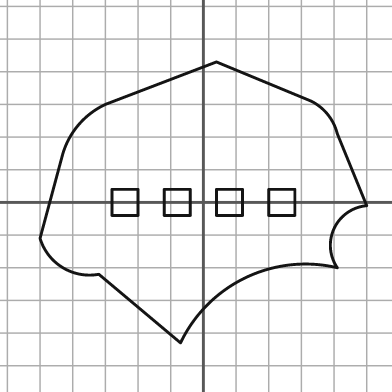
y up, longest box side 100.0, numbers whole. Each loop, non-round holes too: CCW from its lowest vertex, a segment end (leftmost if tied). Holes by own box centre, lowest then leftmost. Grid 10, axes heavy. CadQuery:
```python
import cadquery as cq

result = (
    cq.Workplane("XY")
    .moveTo(-7.0, -43.0)
    .threePointArc((13.0, -23.0), (41.0, -20.0))
    .threePointArc((40.0, -8.0), (50.0, -1.0))
    .lineTo(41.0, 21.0)
    .threePointArc((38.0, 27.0), (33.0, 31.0))
    .lineTo(4.0, 43.0)
    .lineTo(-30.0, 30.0)
    .threePointArc((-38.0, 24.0), (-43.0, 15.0))
    .lineTo(-50.0, -11.0)
    .threePointArc((-43.0, -20.0), (-32.0, -22.0))
    .close()
    .moveTo(-28.0, -4.0)
    .lineTo(-20.0, -4.0)
    .lineTo(-20.0, 4.0)
    .lineTo(-28.0, 4.0)
    .close()
    .moveTo(-12.0, -4.0)
    .lineTo(-4.0, -4.0)
    .lineTo(-4.0, 4.0)
    .lineTo(-12.0, 4.0)
    .close()
    .moveTo(4.0, -4.0)
    .lineTo(12.0, -4.0)
    .lineTo(12.0, 4.0)
    .lineTo(4.0, 4.0)
    .close()
    .moveTo(20.0, -4.0)
    .lineTo(28.0, -4.0)
    .lineTo(28.0, 4.0)
    .lineTo(20.0, 4.0)
    .close()
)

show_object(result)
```